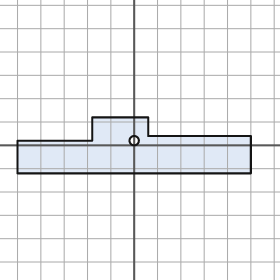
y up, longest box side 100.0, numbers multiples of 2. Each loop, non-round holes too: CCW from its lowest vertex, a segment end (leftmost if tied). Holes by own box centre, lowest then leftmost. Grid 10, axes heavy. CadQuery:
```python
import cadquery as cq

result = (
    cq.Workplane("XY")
    .moveTo(-50.0, -12.0)
    .lineTo(50.0, -12.0)
    .lineTo(50.0, 4.0)
    .lineTo(6.0, 4.0)
    .lineTo(6.0, 12.0)
    .lineTo(-18.0, 12.0)
    .lineTo(-18.0, 2.0)
    .lineTo(-50.0, 2.0)
    .close()
    .moveTo(0.0, 2.0)
    .circle(2.0)
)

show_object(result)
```